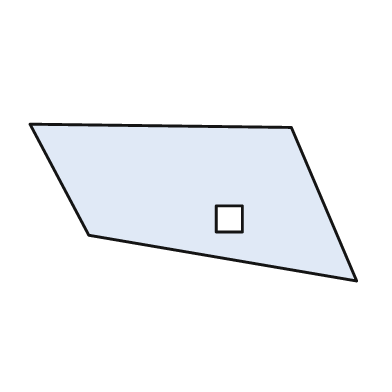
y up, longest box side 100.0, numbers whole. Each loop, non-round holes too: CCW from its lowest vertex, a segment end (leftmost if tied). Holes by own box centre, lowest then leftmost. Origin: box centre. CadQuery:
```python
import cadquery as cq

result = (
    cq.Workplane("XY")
    .moveTo(50.0, -24.0)
    .lineTo(30.0, 23.0)
    .lineTo(-50.0, 24.0)
    .lineTo(-32.0, -10.0)
    .close()
    .moveTo(7.0, -9.0)
    .lineTo(15.0, -9.0)
    .lineTo(15.0, -1.0)
    .lineTo(7.0, -1.0)
    .close()
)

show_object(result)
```